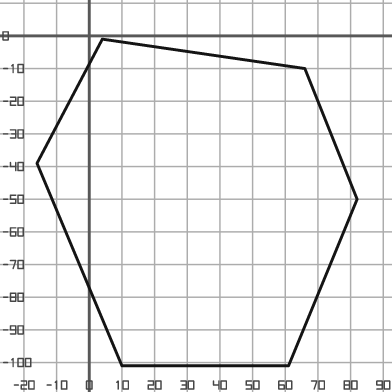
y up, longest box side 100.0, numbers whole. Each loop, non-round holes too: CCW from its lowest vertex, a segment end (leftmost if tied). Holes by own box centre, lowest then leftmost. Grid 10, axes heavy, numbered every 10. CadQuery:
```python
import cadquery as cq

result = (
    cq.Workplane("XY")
    .moveTo(10.0, -101.0)
    .lineTo(61.0, -101.0)
    .lineTo(82.0, -50.0)
    .lineTo(66.0, -10.0)
    .lineTo(4.0, -1.0)
    .lineTo(-16.0, -39.0)
    .close()
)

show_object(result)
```